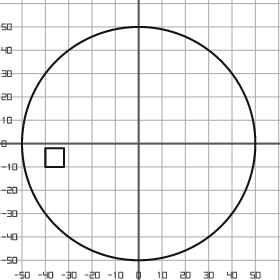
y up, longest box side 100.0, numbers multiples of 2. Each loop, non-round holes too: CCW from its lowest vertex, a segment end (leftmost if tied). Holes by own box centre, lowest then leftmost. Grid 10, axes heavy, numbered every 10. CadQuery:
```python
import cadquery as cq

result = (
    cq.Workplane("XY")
    .moveTo(0.0, 0.0)
    .circle(50.0)
    .moveTo(-40.0, -10.0)
    .lineTo(-32.0, -10.0)
    .lineTo(-32.0, -2.0)
    .lineTo(-40.0, -2.0)
    .close()
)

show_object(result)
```